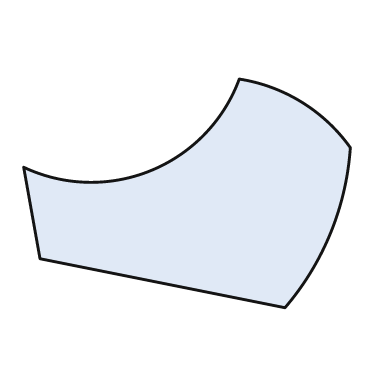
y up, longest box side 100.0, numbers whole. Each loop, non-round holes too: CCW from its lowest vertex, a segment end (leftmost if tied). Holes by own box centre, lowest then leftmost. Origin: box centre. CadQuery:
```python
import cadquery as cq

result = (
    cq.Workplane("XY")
    .moveTo(30.0, -35.0)
    .threePointArc((44.0, -12.0), (50.0, 14.0))
    .threePointArc((35.0, 28.0), (16.0, 35.0))
    .threePointArc((-11.0, 7.0), (-50.0, 8.0))
    .lineTo(-45.0, -20.0)
    .close()
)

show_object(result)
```